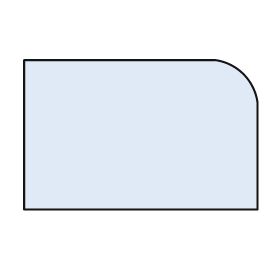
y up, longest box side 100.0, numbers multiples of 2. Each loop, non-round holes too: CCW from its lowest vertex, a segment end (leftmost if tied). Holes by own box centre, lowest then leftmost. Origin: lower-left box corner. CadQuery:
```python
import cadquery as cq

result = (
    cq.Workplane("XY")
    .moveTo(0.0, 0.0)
    .lineTo(100.0, 0.0)
    .lineTo(100.0, 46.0)
    .threePointArc((94.0, 58.0), (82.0, 64.0))
    .lineTo(0.0, 64.0)
    .close()
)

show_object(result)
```